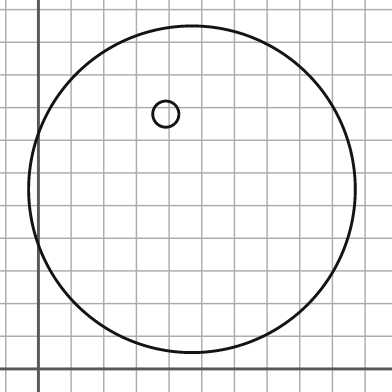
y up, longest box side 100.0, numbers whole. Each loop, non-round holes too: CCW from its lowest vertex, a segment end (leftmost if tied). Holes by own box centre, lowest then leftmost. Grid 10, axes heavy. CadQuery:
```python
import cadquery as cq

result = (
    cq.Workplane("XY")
    .moveTo(47.0, 55.0)
    .circle(50.0)
    .moveTo(39.0, 78.0)
    .circle(4.0)
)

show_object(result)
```